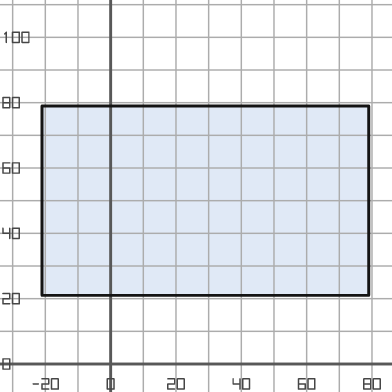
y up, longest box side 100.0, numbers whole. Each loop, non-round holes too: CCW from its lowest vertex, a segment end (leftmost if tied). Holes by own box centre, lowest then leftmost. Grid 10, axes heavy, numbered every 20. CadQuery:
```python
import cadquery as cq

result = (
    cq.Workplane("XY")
    .moveTo(-21.0, 21.0)
    .lineTo(79.0, 21.0)
    .lineTo(79.0, 79.0)
    .lineTo(-21.0, 79.0)
    .close()
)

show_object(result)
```